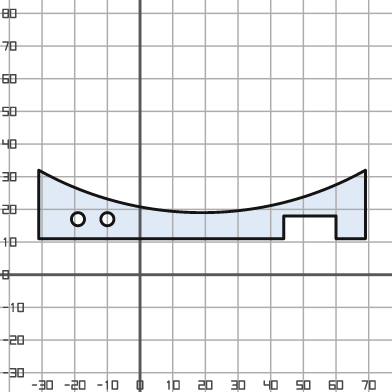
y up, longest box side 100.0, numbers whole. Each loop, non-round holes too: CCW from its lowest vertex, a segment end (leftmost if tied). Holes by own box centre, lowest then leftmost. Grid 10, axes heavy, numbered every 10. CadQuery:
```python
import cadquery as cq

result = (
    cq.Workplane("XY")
    .moveTo(-31.0, 11.0)
    .lineTo(44.0, 11.0)
    .lineTo(44.0, 18.0)
    .lineTo(60.0, 18.0)
    .lineTo(60.0, 11.0)
    .lineTo(69.0, 11.0)
    .lineTo(69.0, 32.0)
    .threePointArc((19.0, 19.0), (-31.0, 32.0))
    .close()
    .moveTo(-19.0, 17.0)
    .circle(2.0)
    .moveTo(-10.0, 17.0)
    .circle(2.0)
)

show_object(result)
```